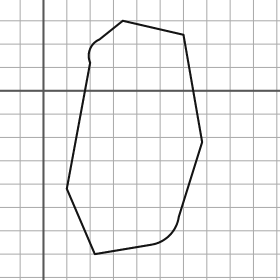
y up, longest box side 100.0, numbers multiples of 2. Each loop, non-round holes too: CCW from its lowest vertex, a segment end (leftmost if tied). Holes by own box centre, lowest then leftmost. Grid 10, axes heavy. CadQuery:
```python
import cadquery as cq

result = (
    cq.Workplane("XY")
    .moveTo(22.0, -70.0)
    .lineTo(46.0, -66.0)
    .threePointArc((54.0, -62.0), (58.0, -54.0))
    .lineTo(68.0, -22.0)
    .lineTo(60.0, 24.0)
    .lineTo(34.0, 30.0)
    .lineTo(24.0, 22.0)
    .threePointArc((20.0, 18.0), (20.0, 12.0))
    .lineTo(10.0, -42.0)
    .close()
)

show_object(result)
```